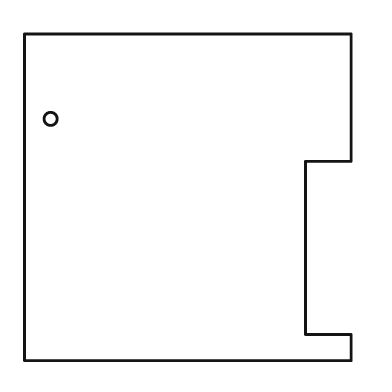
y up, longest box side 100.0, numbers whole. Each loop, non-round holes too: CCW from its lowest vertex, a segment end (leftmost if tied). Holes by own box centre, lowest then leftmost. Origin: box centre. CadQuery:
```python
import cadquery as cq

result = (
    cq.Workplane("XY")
    .moveTo(-50.0, -50.0)
    .lineTo(50.0, -50.0)
    .lineTo(50.0, -42.0)
    .lineTo(36.0, -42.0)
    .lineTo(36.0, 11.0)
    .lineTo(50.0, 11.0)
    .lineTo(50.0, 50.0)
    .lineTo(-50.0, 50.0)
    .close()
    .moveTo(-42.0, 24.0)
    .circle(2.0)
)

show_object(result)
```